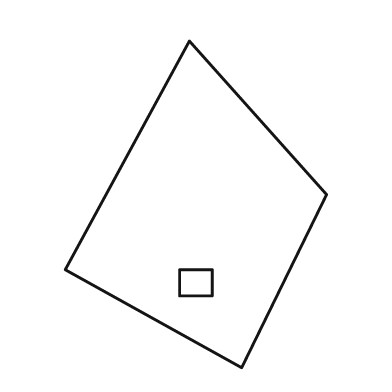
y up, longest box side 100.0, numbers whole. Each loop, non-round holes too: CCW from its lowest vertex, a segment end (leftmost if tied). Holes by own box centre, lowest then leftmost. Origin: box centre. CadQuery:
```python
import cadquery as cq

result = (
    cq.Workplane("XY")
    .moveTo(14.0, -50.0)
    .lineTo(40.0, 3.0)
    .lineTo(-2.0, 50.0)
    .lineTo(-40.0, -20.0)
    .close()
    .moveTo(-5.0, -28.0)
    .lineTo(5.0, -28.0)
    .lineTo(5.0, -20.0)
    .lineTo(-5.0, -20.0)
    .close()
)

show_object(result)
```